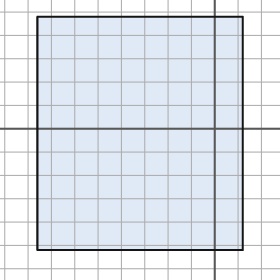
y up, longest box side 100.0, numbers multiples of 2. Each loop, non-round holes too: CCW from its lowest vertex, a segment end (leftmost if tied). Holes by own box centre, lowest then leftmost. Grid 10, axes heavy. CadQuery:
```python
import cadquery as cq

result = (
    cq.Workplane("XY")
    .moveTo(-76.0, -52.0)
    .lineTo(12.0, -52.0)
    .lineTo(12.0, 48.0)
    .lineTo(-76.0, 48.0)
    .close()
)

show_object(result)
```